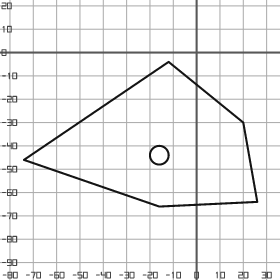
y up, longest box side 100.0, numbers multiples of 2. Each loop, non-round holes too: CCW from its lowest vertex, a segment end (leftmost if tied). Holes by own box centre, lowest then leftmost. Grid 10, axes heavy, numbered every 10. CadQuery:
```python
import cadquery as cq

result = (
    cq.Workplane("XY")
    .moveTo(-16.0, -66.0)
    .lineTo(26.0, -64.0)
    .lineTo(20.0, -30.0)
    .lineTo(-12.0, -4.0)
    .lineTo(-74.0, -46.0)
    .close()
    .moveTo(-16.0, -44.0)
    .circle(4.0)
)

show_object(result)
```